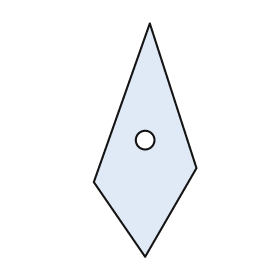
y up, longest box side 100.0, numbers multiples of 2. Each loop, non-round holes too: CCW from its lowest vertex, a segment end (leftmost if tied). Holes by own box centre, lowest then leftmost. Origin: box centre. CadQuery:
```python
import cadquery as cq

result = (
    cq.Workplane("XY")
    .moveTo(0.0, -50.0)
    .lineTo(22.0, -12.0)
    .lineTo(2.0, 50.0)
    .lineTo(-22.0, -18.0)
    .close()
    .moveTo(0.0, 0.0)
    .circle(4.0)
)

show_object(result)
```